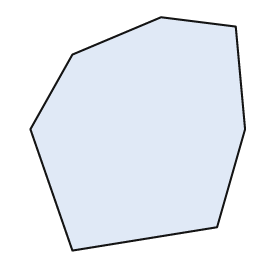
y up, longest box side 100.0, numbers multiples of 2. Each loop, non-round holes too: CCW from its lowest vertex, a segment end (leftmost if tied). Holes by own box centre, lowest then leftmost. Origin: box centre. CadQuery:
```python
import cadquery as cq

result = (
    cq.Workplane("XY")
    .moveTo(-28.0, -50.0)
    .lineTo(34.0, -40.0)
    .lineTo(46.0, 2.0)
    .lineTo(42.0, 46.0)
    .lineTo(10.0, 50.0)
    .lineTo(-28.0, 34.0)
    .lineTo(-46.0, 2.0)
    .close()
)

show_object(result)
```